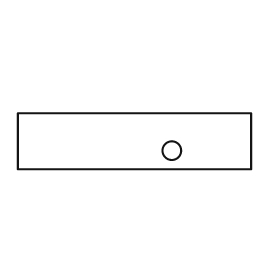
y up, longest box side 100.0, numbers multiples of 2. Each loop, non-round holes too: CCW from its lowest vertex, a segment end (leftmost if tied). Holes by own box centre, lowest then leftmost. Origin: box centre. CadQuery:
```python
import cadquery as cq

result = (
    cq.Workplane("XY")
    .moveTo(-50.0, -12.0)
    .lineTo(50.0, -12.0)
    .lineTo(50.0, 12.0)
    .lineTo(-50.0, 12.0)
    .close()
    .moveTo(16.0, -4.0)
    .circle(4.0)
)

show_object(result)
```